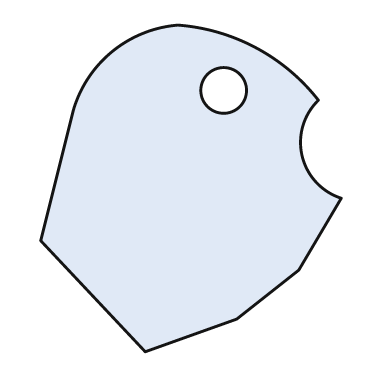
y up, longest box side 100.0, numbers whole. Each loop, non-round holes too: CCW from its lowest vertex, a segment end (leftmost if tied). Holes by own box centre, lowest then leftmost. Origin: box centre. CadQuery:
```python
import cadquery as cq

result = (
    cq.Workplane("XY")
    .moveTo(-14.0, -50.0)
    .lineTo(14.0, -40.0)
    .lineTo(33.0, -25.0)
    .lineTo(46.0, -3.0)
    .threePointArc((34.0, 10.0), (39.0, 27.0))
    .threePointArc((20.0, 43.0), (-4.0, 50.0))
    .threePointArc((-24.0, 42.0), (-36.0, 24.0))
    .lineTo(-46.0, -16.0)
    .close()
    .moveTo(10.0, 30.0)
    .circle(7.0)
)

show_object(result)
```